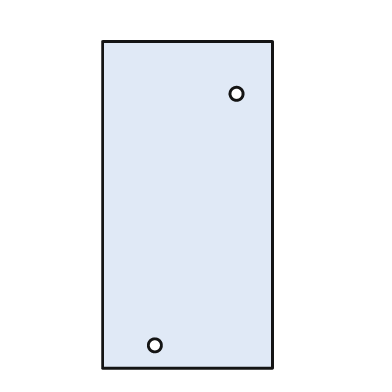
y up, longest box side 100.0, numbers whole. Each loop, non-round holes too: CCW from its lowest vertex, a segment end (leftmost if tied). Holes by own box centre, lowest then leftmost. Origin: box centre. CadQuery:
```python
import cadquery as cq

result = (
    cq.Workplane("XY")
    .moveTo(-26.0, -50.0)
    .lineTo(26.0, -50.0)
    .lineTo(26.0, 50.0)
    .lineTo(-26.0, 50.0)
    .close()
    .moveTo(-10.0, -43.0)
    .circle(2.0)
    .moveTo(15.0, 34.0)
    .circle(2.0)
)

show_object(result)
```